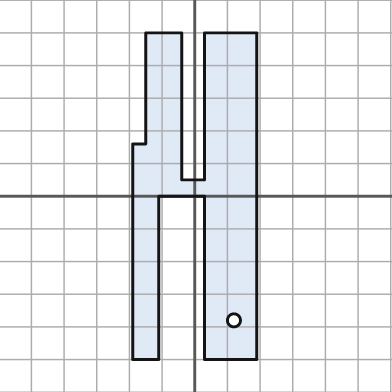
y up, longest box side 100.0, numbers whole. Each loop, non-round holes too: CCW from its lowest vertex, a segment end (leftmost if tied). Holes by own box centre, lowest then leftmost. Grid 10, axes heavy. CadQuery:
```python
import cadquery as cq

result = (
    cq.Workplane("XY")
    .moveTo(-19.0, -50.0)
    .lineTo(-11.0, -50.0)
    .lineTo(-11.0, 0.0)
    .lineTo(3.0, 0.0)
    .lineTo(3.0, -50.0)
    .lineTo(19.0, -50.0)
    .lineTo(19.0, 50.0)
    .lineTo(3.0, 50.0)
    .lineTo(3.0, 5.0)
    .lineTo(-4.0, 5.0)
    .lineTo(-4.0, 50.0)
    .lineTo(-15.0, 50.0)
    .lineTo(-15.0, 16.0)
    .lineTo(-19.0, 16.0)
    .close()
    .moveTo(12.0, -38.0)
    .circle(2.0)
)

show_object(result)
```